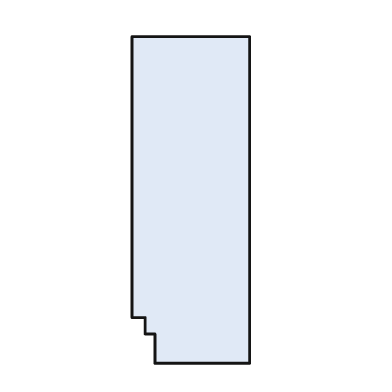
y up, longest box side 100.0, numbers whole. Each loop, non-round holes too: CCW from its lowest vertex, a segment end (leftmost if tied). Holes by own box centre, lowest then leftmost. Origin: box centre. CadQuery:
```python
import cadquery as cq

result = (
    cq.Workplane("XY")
    .moveTo(-11.0, -50.0)
    .lineTo(18.0, -50.0)
    .lineTo(18.0, 50.0)
    .lineTo(-18.0, 50.0)
    .lineTo(-18.0, -36.0)
    .lineTo(-14.0, -36.0)
    .lineTo(-14.0, -41.0)
    .lineTo(-11.0, -41.0)
    .close()
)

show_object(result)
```